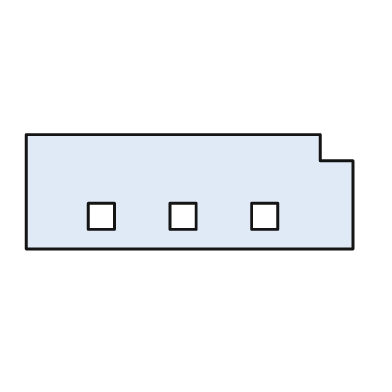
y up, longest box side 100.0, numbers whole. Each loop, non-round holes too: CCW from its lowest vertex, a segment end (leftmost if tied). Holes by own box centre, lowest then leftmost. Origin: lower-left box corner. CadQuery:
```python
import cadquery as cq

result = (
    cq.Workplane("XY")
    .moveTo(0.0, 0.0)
    .lineTo(100.0, 0.0)
    .lineTo(100.0, 27.0)
    .lineTo(90.0, 27.0)
    .lineTo(90.0, 35.0)
    .lineTo(0.0, 35.0)
    .close()
    .moveTo(19.0, 6.0)
    .lineTo(27.0, 6.0)
    .lineTo(27.0, 14.0)
    .lineTo(19.0, 14.0)
    .close()
    .moveTo(44.0, 6.0)
    .lineTo(52.0, 6.0)
    .lineTo(52.0, 14.0)
    .lineTo(44.0, 14.0)
    .close()
    .moveTo(69.0, 6.0)
    .lineTo(77.0, 6.0)
    .lineTo(77.0, 14.0)
    .lineTo(69.0, 14.0)
    .close()
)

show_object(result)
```